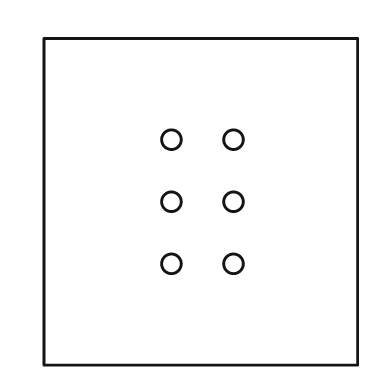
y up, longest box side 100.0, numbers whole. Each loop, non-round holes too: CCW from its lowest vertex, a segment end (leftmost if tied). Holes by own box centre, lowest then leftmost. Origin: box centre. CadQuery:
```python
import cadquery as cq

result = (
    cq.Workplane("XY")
    .moveTo(-48.0, -50.0)
    .lineTo(48.0, -50.0)
    .lineTo(48.0, 50.0)
    .lineTo(-48.0, 50.0)
    .close()
    .moveTo(-9.0, -19.0)
    .circle(3.0)
    .moveTo(10.0, -19.0)
    .circle(3.0)
    .moveTo(-9.0, 0.0)
    .circle(3.0)
    .moveTo(10.0, 0.0)
    .circle(3.0)
    .moveTo(-9.0, 19.0)
    .circle(3.0)
    .moveTo(10.0, 19.0)
    .circle(3.0)
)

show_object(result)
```